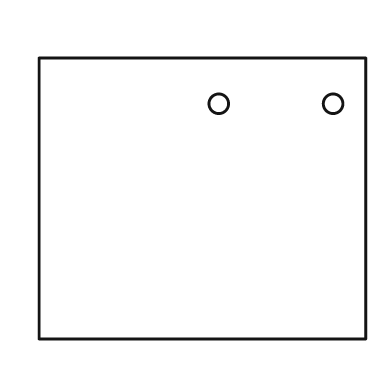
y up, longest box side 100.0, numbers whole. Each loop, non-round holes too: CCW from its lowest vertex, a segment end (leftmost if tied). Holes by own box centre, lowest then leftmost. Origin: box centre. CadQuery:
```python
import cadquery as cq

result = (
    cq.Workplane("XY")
    .moveTo(-50.0, -43.0)
    .lineTo(50.0, -43.0)
    .lineTo(50.0, 43.0)
    .lineTo(-50.0, 43.0)
    .close()
    .moveTo(5.0, 29.0)
    .circle(3.0)
    .moveTo(40.0, 29.0)
    .circle(3.0)
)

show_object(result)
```